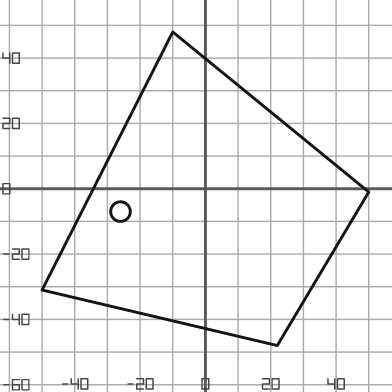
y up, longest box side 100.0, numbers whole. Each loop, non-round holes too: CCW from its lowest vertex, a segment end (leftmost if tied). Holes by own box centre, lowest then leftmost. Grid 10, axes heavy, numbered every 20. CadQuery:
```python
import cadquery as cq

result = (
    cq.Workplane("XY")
    .moveTo(22.0, -48.0)
    .lineTo(50.0, -1.0)
    .lineTo(-10.0, 48.0)
    .lineTo(-50.0, -31.0)
    .close()
    .moveTo(-26.0, -7.0)
    .circle(3.0)
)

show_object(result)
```